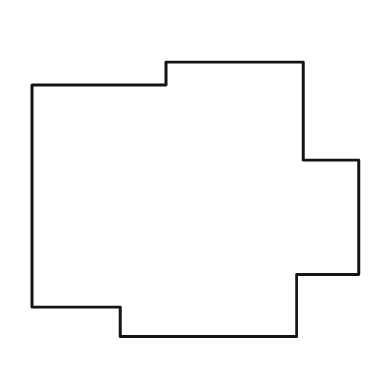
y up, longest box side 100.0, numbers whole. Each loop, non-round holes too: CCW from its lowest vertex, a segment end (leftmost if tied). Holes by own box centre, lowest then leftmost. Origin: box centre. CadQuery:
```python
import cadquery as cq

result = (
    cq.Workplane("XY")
    .moveTo(-23.0, -42.0)
    .lineTo(31.0, -42.0)
    .lineTo(31.0, -23.0)
    .lineTo(50.0, -23.0)
    .lineTo(50.0, 12.0)
    .lineTo(33.0, 12.0)
    .lineTo(33.0, 42.0)
    .lineTo(-9.0, 42.0)
    .lineTo(-9.0, 35.0)
    .lineTo(-50.0, 35.0)
    .lineTo(-50.0, -33.0)
    .lineTo(-23.0, -33.0)
    .close()
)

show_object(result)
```